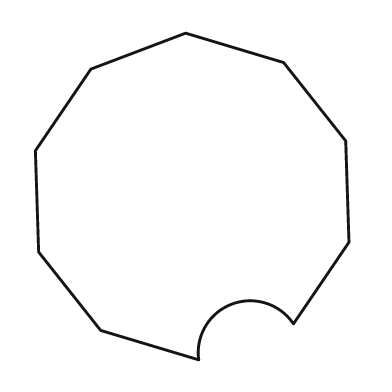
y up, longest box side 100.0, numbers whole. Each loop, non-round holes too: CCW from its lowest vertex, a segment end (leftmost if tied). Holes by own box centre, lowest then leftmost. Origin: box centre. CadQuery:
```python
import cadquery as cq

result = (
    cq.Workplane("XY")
    .moveTo(2.0, -50.0)
    .threePointArc((12.0, -33.0), (31.0, -39.0))
    .lineTo(48.0, -14.0)
    .lineTo(47.0, 17.0)
    .lineTo(28.0, 41.0)
    .lineTo(-2.0, 50.0)
    .lineTo(-31.0, 39.0)
    .lineTo(-48.0, 14.0)
    .lineTo(-47.0, -17.0)
    .lineTo(-28.0, -41.0)
    .close()
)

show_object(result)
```